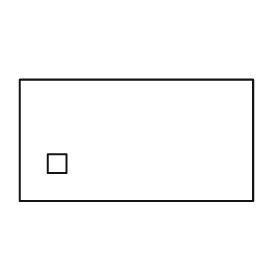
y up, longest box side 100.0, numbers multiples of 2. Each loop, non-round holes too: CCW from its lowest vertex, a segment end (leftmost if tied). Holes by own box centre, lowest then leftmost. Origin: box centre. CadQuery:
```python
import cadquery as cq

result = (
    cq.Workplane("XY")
    .moveTo(-50.0, -26.0)
    .lineTo(50.0, -26.0)
    .lineTo(50.0, 26.0)
    .lineTo(-50.0, 26.0)
    .close()
    .moveTo(-38.0, -14.0)
    .lineTo(-30.0, -14.0)
    .lineTo(-30.0, -6.0)
    .lineTo(-38.0, -6.0)
    .close()
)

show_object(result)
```